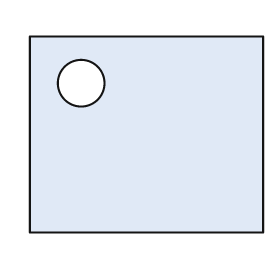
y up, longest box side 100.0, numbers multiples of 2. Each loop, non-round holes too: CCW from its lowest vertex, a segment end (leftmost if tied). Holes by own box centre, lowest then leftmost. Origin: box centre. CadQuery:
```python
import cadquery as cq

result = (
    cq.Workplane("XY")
    .moveTo(-50.0, -42.0)
    .lineTo(50.0, -42.0)
    .lineTo(50.0, 42.0)
    .lineTo(-50.0, 42.0)
    .close()
    .moveTo(-28.0, 22.0)
    .circle(10.0)
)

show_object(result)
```